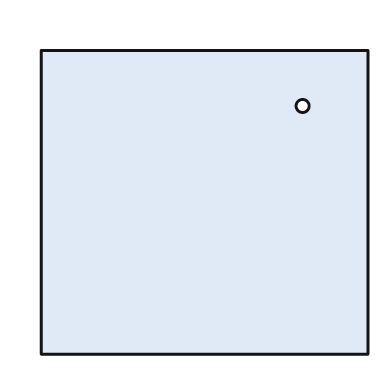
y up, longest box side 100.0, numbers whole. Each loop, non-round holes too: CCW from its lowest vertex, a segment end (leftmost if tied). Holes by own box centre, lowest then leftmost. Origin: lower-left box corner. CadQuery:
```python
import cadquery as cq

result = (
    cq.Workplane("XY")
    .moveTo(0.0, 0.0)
    .lineTo(100.0, 0.0)
    .lineTo(100.0, 93.0)
    .lineTo(0.0, 93.0)
    .close()
    .moveTo(80.0, 76.0)
    .circle(2.0)
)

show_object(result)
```